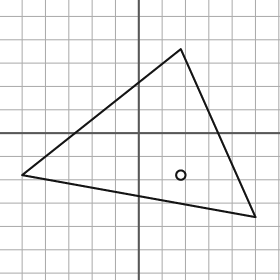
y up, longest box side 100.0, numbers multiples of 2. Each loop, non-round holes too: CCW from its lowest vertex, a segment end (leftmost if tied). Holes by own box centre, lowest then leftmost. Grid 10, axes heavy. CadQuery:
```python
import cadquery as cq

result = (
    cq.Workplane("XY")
    .moveTo(50.0, -36.0)
    .lineTo(18.0, 36.0)
    .lineTo(-50.0, -18.0)
    .close()
    .moveTo(18.0, -18.0)
    .circle(2.0)
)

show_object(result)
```